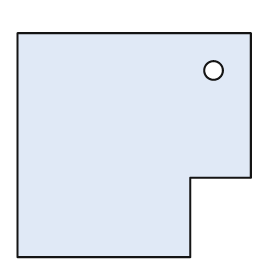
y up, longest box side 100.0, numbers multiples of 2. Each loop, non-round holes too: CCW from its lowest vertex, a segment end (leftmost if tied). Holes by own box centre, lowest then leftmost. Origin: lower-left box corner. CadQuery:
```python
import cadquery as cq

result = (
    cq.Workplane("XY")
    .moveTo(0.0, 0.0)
    .lineTo(74.0, 0.0)
    .lineTo(74.0, 34.0)
    .lineTo(100.0, 34.0)
    .lineTo(100.0, 96.0)
    .lineTo(0.0, 96.0)
    .close()
    .moveTo(84.0, 80.0)
    .circle(4.0)
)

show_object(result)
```